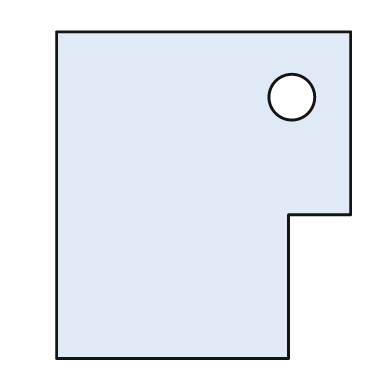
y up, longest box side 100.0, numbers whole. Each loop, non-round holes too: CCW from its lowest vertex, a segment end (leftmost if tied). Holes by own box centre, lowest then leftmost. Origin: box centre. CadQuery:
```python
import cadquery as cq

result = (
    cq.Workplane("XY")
    .moveTo(-45.0, -50.0)
    .lineTo(26.0, -50.0)
    .lineTo(26.0, -6.0)
    .lineTo(45.0, -6.0)
    .lineTo(45.0, 50.0)
    .lineTo(-45.0, 50.0)
    .close()
    .moveTo(27.0, 30.0)
    .circle(7.0)
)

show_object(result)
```